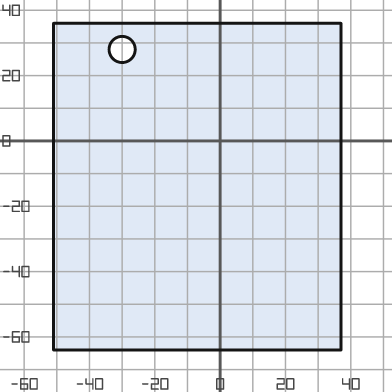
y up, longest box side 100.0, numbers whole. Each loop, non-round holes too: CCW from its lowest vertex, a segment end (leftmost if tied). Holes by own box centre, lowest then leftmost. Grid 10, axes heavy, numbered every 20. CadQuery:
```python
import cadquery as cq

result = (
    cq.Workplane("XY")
    .moveTo(-51.0, -64.0)
    .lineTo(37.0, -64.0)
    .lineTo(37.0, 36.0)
    .lineTo(-51.0, 36.0)
    .close()
    .moveTo(-30.0, 28.0)
    .circle(4.0)
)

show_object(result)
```